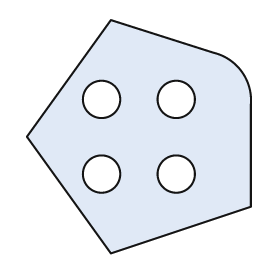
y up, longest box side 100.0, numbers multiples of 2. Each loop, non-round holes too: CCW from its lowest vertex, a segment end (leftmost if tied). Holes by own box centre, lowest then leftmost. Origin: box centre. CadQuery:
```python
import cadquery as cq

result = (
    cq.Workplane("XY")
    .moveTo(-12.0, -50.0)
    .lineTo(48.0, -30.0)
    .lineTo(48.0, 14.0)
    .threePointArc((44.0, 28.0), (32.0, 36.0))
    .lineTo(-12.0, 50.0)
    .lineTo(-48.0, 0.0)
    .close()
    .moveTo(-16.0, -16.0)
    .circle(8.0)
    .moveTo(16.0, -16.0)
    .circle(8.0)
    .moveTo(-16.0, 16.0)
    .circle(8.0)
    .moveTo(16.0, 16.0)
    .circle(8.0)
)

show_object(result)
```